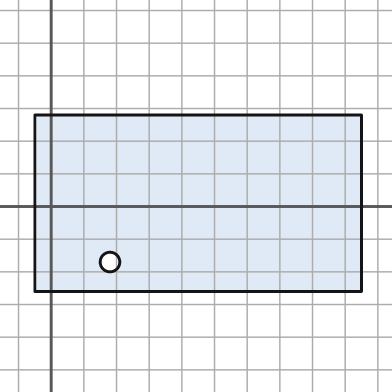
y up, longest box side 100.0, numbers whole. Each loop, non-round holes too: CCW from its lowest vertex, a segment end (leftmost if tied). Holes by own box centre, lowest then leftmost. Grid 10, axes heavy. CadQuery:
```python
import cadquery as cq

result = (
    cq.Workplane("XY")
    .moveTo(-5.0, -26.0)
    .lineTo(95.0, -26.0)
    .lineTo(95.0, 28.0)
    .lineTo(-5.0, 28.0)
    .close()
    .moveTo(18.0, -17.0)
    .circle(3.0)
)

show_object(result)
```